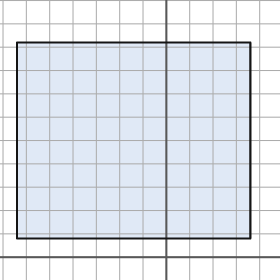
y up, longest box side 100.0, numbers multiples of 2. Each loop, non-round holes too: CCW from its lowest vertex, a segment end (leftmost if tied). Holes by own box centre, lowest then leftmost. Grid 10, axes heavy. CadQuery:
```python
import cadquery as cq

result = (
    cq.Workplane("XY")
    .moveTo(-64.0, 8.0)
    .lineTo(36.0, 8.0)
    .lineTo(36.0, 92.0)
    .lineTo(-64.0, 92.0)
    .close()
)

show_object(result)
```